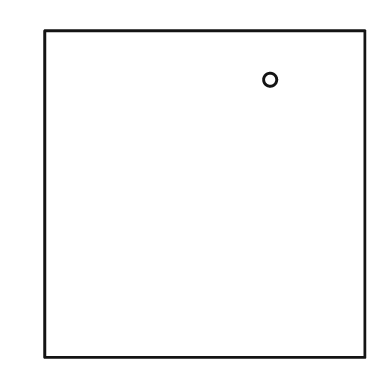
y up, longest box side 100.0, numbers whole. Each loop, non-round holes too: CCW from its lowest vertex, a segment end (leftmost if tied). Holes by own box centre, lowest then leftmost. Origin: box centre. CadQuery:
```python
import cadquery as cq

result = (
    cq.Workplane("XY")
    .moveTo(-49.0, -50.0)
    .lineTo(49.0, -50.0)
    .lineTo(49.0, 50.0)
    .lineTo(-49.0, 50.0)
    .close()
    .moveTo(20.0, 35.0)
    .circle(2.0)
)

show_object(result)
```